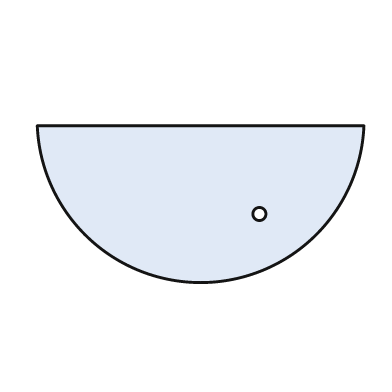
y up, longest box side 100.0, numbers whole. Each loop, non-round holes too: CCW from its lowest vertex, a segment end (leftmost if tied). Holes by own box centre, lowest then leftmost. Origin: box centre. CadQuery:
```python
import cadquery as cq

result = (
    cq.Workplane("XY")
    .moveTo(-50.0, 24.0)
    .threePointArc((0.0, -24.0), (50.0, 24.0))
    .close()
    .moveTo(18.0, -3.0)
    .circle(2.0)
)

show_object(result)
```